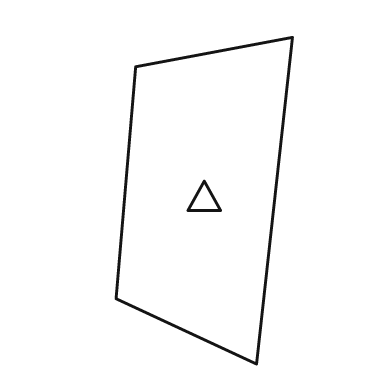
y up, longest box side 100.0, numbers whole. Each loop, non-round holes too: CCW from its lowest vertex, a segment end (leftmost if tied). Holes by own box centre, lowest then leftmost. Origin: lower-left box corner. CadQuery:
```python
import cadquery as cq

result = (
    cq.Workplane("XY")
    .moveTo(43.0, 0.0)
    .lineTo(54.0, 100.0)
    .lineTo(6.0, 91.0)
    .lineTo(0.0, 20.0)
    .close()
    .moveTo(22.0, 47.0)
    .lineTo(32.0, 47.0)
    .lineTo(27.0, 56.0)
    .close()
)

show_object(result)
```